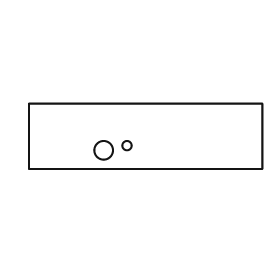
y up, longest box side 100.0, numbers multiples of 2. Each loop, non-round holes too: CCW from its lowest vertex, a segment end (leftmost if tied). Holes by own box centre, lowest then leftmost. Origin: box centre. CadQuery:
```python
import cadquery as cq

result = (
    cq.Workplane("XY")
    .moveTo(-50.0, -14.0)
    .lineTo(50.0, -14.0)
    .lineTo(50.0, 14.0)
    .lineTo(-50.0, 14.0)
    .close()
    .moveTo(-18.0, -6.0)
    .circle(4.0)
    .moveTo(-8.0, -4.0)
    .circle(2.0)
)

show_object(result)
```